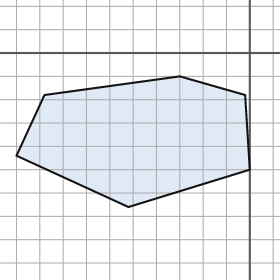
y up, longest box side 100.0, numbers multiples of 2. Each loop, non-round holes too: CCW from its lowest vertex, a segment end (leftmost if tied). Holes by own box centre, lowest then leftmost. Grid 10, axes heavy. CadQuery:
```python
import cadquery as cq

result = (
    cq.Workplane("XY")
    .moveTo(-52.0, -66.0)
    .lineTo(0.0, -50.0)
    .lineTo(-2.0, -18.0)
    .lineTo(-30.0, -10.0)
    .lineTo(-88.0, -18.0)
    .lineTo(-100.0, -44.0)
    .close()
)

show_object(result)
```